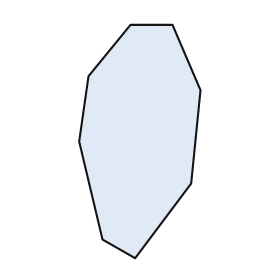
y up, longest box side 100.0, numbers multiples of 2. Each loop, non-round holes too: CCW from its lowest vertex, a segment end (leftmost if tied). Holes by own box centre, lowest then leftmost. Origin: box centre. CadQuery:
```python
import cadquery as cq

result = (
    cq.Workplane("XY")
    .moveTo(-2.0, -50.0)
    .lineTo(22.0, -18.0)
    .lineTo(26.0, 22.0)
    .lineTo(14.0, 50.0)
    .lineTo(-4.0, 50.0)
    .lineTo(-22.0, 28.0)
    .lineTo(-26.0, 0.0)
    .lineTo(-16.0, -42.0)
    .close()
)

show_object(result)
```